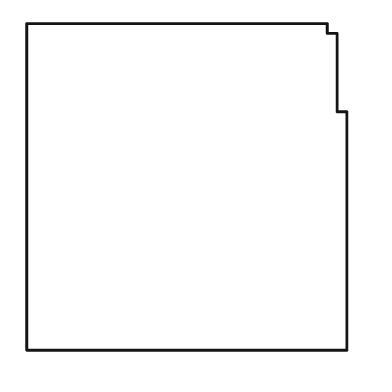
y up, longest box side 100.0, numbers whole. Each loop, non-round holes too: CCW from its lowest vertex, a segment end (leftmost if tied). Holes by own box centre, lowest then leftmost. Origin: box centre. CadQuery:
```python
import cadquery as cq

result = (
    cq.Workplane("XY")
    .moveTo(-49.0, -50.0)
    .lineTo(49.0, -50.0)
    .lineTo(49.0, 23.0)
    .lineTo(46.0, 23.0)
    .lineTo(46.0, 47.0)
    .lineTo(43.0, 47.0)
    .lineTo(43.0, 50.0)
    .lineTo(-49.0, 50.0)
    .close()
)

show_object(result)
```